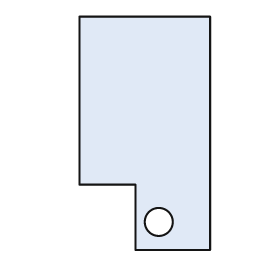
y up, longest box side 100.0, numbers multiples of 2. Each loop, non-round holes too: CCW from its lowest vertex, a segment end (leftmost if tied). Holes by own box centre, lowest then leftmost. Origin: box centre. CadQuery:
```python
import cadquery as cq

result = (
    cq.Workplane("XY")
    .moveTo(-4.0, -50.0)
    .lineTo(28.0, -50.0)
    .lineTo(28.0, 50.0)
    .lineTo(-28.0, 50.0)
    .lineTo(-28.0, -22.0)
    .lineTo(-4.0, -22.0)
    .close()
    .moveTo(6.0, -38.0)
    .circle(6.0)
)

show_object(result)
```